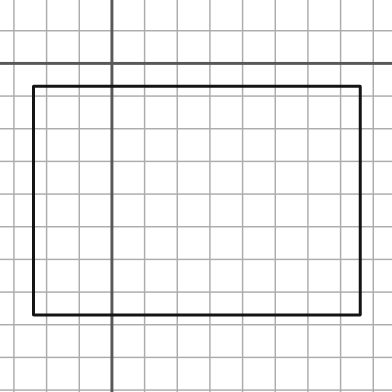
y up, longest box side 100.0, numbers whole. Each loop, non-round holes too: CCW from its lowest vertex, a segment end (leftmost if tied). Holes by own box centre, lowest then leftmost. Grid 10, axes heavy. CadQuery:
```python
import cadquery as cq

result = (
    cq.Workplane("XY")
    .moveTo(-24.0, -77.0)
    .lineTo(76.0, -77.0)
    .lineTo(76.0, -7.0)
    .lineTo(-24.0, -7.0)
    .close()
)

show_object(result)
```